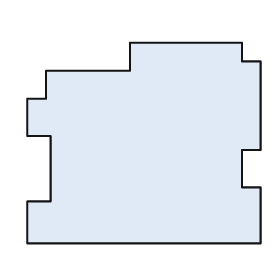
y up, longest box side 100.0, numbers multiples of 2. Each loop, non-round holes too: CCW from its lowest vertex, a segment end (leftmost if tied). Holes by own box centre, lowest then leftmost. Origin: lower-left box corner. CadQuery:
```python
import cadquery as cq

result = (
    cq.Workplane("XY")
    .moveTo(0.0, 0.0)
    .lineTo(100.0, 0.0)
    .lineTo(100.0, 24.0)
    .lineTo(92.0, 24.0)
    .lineTo(92.0, 40.0)
    .lineTo(100.0, 40.0)
    .lineTo(100.0, 78.0)
    .lineTo(92.0, 78.0)
    .lineTo(92.0, 86.0)
    .lineTo(44.0, 86.0)
    .lineTo(44.0, 74.0)
    .lineTo(8.0, 74.0)
    .lineTo(8.0, 62.0)
    .lineTo(0.0, 62.0)
    .lineTo(0.0, 46.0)
    .lineTo(10.0, 46.0)
    .lineTo(10.0, 18.0)
    .lineTo(0.0, 18.0)
    .close()
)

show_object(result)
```